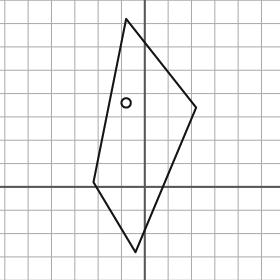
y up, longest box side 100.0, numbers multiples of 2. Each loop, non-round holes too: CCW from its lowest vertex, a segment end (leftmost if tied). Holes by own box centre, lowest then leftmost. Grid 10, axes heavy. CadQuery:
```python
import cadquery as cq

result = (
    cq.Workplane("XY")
    .moveTo(-4.0, -28.0)
    .lineTo(22.0, 34.0)
    .lineTo(-8.0, 72.0)
    .lineTo(-22.0, 2.0)
    .close()
    .moveTo(-8.0, 36.0)
    .circle(2.0)
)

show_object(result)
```